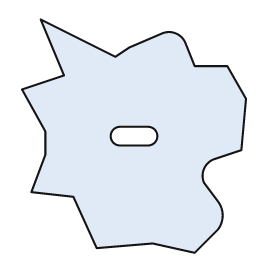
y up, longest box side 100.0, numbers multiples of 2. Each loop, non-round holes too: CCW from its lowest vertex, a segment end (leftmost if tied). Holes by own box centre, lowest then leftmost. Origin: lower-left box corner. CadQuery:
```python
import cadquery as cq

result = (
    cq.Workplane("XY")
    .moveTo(74.0, 0.0)
    .lineTo(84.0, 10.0)
    .threePointArc((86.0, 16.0), (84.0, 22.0))
    .lineTo(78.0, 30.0)
    .threePointArc((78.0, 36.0), (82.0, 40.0))
    .lineTo(94.0, 44.0)
    .lineTo(96.0, 66.0)
    .lineTo(88.0, 80.0)
    .lineTo(74.0, 80.0)
    .lineTo(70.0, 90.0)
    .threePointArc((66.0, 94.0), (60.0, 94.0))
    .lineTo(46.0, 88.0)
    .lineTo(40.0, 84.0)
    .lineTo(8.0, 100.0)
    .lineTo(18.0, 76.0)
    .lineTo(0.0, 70.0)
    .lineTo(10.0, 52.0)
    .lineTo(10.0, 42.0)
    .lineTo(4.0, 26.0)
    .lineTo(22.0, 24.0)
    .lineTo(32.0, 2.0)
    .lineTo(56.0, 4.0)
    .close()
    .moveTo(42.0, 46.0)
    .lineTo(54.0, 46.0)
    .threePointArc((58.0, 50.0), (54.0, 54.0))
    .lineTo(42.0, 54.0)
    .threePointArc((38.0, 50.0), (42.0, 46.0))
    .close()
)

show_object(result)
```